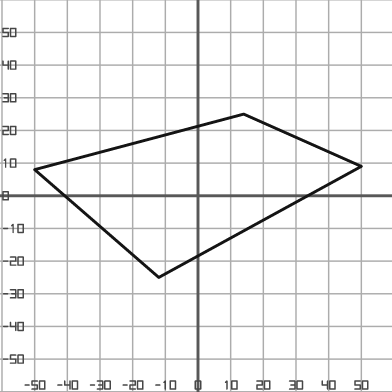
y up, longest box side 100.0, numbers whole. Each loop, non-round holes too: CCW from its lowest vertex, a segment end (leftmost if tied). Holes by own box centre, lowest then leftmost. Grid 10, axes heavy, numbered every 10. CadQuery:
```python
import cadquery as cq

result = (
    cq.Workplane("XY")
    .moveTo(-12.0, -25.0)
    .lineTo(50.0, 9.0)
    .lineTo(14.0, 25.0)
    .lineTo(-50.0, 8.0)
    .close()
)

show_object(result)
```